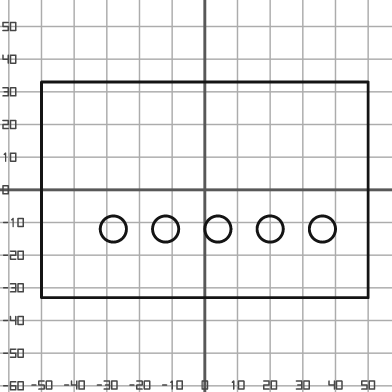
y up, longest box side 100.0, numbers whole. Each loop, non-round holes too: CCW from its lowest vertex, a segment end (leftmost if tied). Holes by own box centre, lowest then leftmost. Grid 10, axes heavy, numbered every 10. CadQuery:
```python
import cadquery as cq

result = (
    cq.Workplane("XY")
    .moveTo(-50.0, -33.0)
    .lineTo(50.0, -33.0)
    .lineTo(50.0, 33.0)
    .lineTo(-50.0, 33.0)
    .close()
    .moveTo(-28.0, -12.0)
    .circle(4.0)
    .moveTo(-12.0, -12.0)
    .circle(4.0)
    .moveTo(4.0, -12.0)
    .circle(4.0)
    .moveTo(20.0, -12.0)
    .circle(4.0)
    .moveTo(36.0, -12.0)
    .circle(4.0)
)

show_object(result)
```